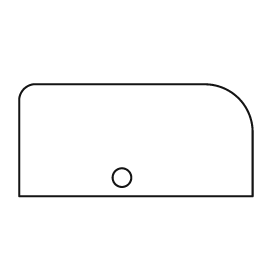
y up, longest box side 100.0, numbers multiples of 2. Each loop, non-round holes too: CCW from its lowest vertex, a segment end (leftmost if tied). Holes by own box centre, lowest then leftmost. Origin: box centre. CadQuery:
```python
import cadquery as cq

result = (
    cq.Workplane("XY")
    .moveTo(-50.0, -24.0)
    .lineTo(50.0, -24.0)
    .lineTo(50.0, 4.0)
    .threePointArc((44.0, 18.0), (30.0, 24.0))
    .lineTo(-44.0, 24.0)
    .threePointArc((-48.0, 22.0), (-50.0, 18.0))
    .close()
    .moveTo(-6.0, -16.0)
    .circle(4.0)
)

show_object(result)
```